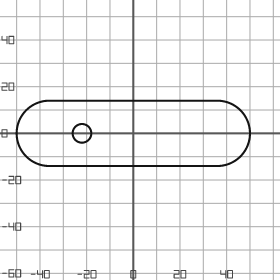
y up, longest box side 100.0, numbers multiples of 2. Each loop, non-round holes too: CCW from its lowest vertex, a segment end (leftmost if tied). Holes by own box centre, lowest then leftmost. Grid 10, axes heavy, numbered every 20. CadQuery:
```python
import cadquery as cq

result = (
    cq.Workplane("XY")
    .moveTo(-36.0, -14.0)
    .lineTo(36.0, -14.0)
    .threePointArc((50.0, 0.0), (36.0, 14.0))
    .lineTo(-36.0, 14.0)
    .threePointArc((-50.0, 0.0), (-36.0, -14.0))
    .close()
    .moveTo(-22.0, 0.0)
    .circle(4.0)
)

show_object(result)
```